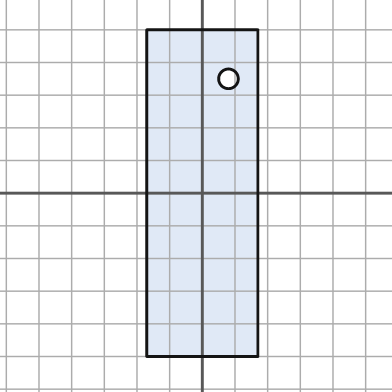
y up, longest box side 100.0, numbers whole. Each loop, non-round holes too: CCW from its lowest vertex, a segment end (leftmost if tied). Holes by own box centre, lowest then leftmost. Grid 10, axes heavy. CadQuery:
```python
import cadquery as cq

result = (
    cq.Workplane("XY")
    .moveTo(-17.0, -50.0)
    .lineTo(17.0, -50.0)
    .lineTo(17.0, 50.0)
    .lineTo(-17.0, 50.0)
    .close()
    .moveTo(8.0, 35.0)
    .circle(3.0)
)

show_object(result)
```